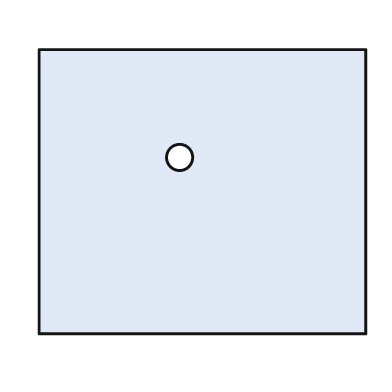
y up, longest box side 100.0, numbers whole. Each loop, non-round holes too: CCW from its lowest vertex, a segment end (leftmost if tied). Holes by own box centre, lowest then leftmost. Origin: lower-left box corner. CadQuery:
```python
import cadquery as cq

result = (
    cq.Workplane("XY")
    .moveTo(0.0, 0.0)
    .lineTo(100.0, 0.0)
    .lineTo(100.0, 87.0)
    .lineTo(0.0, 87.0)
    .close()
    .moveTo(43.0, 54.0)
    .circle(4.0)
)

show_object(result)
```